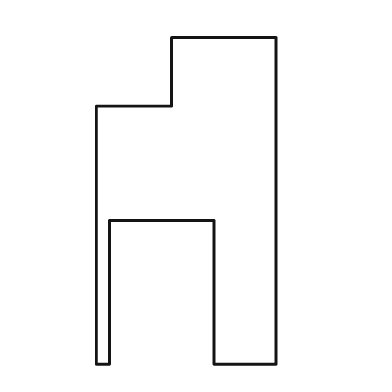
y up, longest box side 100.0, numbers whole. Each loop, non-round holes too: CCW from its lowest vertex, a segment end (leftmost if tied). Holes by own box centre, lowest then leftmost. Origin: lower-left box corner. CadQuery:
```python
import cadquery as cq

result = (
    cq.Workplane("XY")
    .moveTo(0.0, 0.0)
    .lineTo(4.0, 0.0)
    .lineTo(4.0, 44.0)
    .lineTo(36.0, 44.0)
    .lineTo(36.0, 0.0)
    .lineTo(55.0, 0.0)
    .lineTo(55.0, 100.0)
    .lineTo(23.0, 100.0)
    .lineTo(23.0, 79.0)
    .lineTo(0.0, 79.0)
    .close()
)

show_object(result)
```